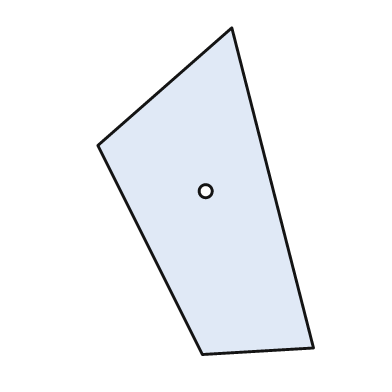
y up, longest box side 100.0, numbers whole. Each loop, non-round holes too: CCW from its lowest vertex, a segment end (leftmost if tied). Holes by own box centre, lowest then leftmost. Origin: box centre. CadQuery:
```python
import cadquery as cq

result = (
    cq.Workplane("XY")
    .moveTo(-1.0, -50.0)
    .lineTo(33.0, -48.0)
    .lineTo(8.0, 50.0)
    .lineTo(-33.0, 14.0)
    .close()
    .moveTo(0.0, 0.0)
    .circle(2.0)
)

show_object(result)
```